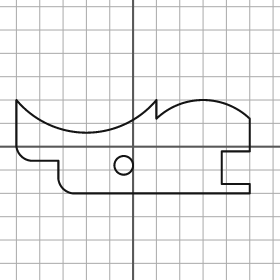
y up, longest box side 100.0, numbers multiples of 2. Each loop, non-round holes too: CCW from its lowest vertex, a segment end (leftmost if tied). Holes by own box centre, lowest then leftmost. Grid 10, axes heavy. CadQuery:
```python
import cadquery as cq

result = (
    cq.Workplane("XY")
    .moveTo(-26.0, -20.0)
    .lineTo(50.0, -20.0)
    .lineTo(50.0, -16.0)
    .lineTo(38.0, -16.0)
    .lineTo(38.0, -2.0)
    .lineTo(50.0, -2.0)
    .lineTo(50.0, 12.0)
    .threePointArc((30.0, 20.0), (10.0, 12.0))
    .lineTo(10.0, 20.0)
    .threePointArc((-20.0, 6.0), (-50.0, 20.0))
    .lineTo(-50.0, 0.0)
    .threePointArc((-48.0, -4.0), (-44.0, -6.0))
    .lineTo(-32.0, -6.0)
    .lineTo(-32.0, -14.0)
    .threePointArc((-30.0, -18.0), (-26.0, -20.0))
    .close()
    .moveTo(-4.0, -8.0)
    .circle(4.0)
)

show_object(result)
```